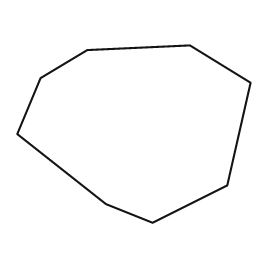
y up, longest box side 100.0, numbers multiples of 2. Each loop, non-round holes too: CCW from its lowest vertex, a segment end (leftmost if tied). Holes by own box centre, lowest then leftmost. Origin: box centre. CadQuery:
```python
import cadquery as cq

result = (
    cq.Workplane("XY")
    .moveTo(8.0, -38.0)
    .lineTo(40.0, -22.0)
    .lineTo(50.0, 22.0)
    .lineTo(24.0, 38.0)
    .lineTo(-20.0, 36.0)
    .lineTo(-40.0, 24.0)
    .lineTo(-50.0, 0.0)
    .lineTo(-12.0, -30.0)
    .close()
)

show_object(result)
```